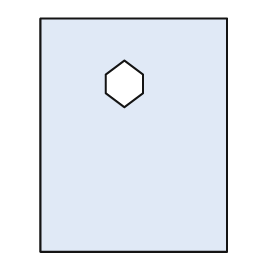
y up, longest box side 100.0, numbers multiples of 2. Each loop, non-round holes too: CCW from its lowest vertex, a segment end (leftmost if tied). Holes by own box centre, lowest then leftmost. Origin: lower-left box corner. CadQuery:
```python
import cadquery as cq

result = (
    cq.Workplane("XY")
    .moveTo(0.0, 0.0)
    .lineTo(80.0, 0.0)
    .lineTo(80.0, 100.0)
    .lineTo(0.0, 100.0)
    .close()
    .moveTo(36.0, 62.0)
    .lineTo(44.0, 68.0)
    .lineTo(44.0, 76.0)
    .lineTo(36.0, 82.0)
    .lineTo(28.0, 76.0)
    .lineTo(28.0, 68.0)
    .close()
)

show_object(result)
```